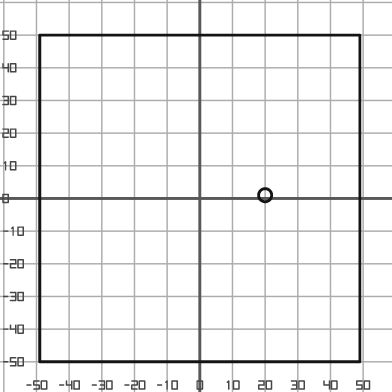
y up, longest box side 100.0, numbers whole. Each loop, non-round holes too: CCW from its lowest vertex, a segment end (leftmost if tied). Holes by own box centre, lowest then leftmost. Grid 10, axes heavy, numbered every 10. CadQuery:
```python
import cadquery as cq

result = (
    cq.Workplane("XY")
    .moveTo(-49.0, -50.0)
    .lineTo(49.0, -50.0)
    .lineTo(49.0, 50.0)
    .lineTo(-49.0, 50.0)
    .close()
    .moveTo(20.0, 1.0)
    .circle(2.0)
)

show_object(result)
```